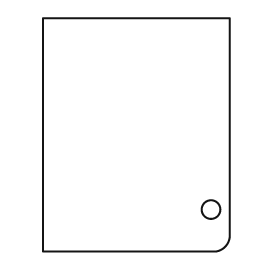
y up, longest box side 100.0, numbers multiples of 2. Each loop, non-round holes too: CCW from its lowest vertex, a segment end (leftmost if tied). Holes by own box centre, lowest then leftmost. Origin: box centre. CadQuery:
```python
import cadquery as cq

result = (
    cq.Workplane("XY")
    .moveTo(-40.0, -50.0)
    .lineTo(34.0, -50.0)
    .threePointArc((38.0, -48.0), (40.0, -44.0))
    .lineTo(40.0, 50.0)
    .lineTo(-40.0, 50.0)
    .close()
    .moveTo(32.0, -32.0)
    .circle(4.0)
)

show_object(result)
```